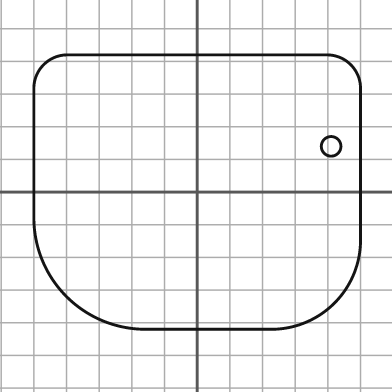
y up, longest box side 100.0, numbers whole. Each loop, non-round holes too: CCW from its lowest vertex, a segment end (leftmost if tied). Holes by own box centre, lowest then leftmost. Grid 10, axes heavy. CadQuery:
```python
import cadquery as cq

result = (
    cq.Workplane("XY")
    .moveTo(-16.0, -42.0)
    .lineTo(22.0, -42.0)
    .threePointArc((42.0, -34.0), (50.0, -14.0))
    .lineTo(50.0, 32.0)
    .threePointArc((47.0, 39.0), (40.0, 42.0))
    .lineTo(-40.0, 42.0)
    .threePointArc((-47.0, 39.0), (-50.0, 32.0))
    .lineTo(-50.0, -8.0)
    .threePointArc((-40.0, -32.0), (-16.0, -42.0))
    .close()
    .moveTo(41.0, 14.0)
    .circle(3.0)
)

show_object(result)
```